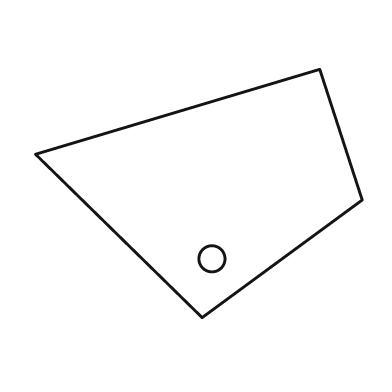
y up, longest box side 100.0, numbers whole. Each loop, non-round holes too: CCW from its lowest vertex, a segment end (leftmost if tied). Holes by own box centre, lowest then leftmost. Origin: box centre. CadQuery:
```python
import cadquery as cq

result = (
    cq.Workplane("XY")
    .moveTo(1.0, -38.0)
    .lineTo(50.0, -2.0)
    .lineTo(37.0, 38.0)
    .lineTo(-50.0, 12.0)
    .close()
    .moveTo(4.0, -20.0)
    .circle(4.0)
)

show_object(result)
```